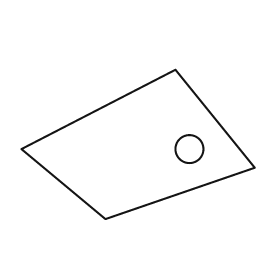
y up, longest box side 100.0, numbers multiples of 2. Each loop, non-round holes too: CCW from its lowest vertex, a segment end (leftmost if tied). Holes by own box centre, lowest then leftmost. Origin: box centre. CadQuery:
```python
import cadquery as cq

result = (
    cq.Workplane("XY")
    .moveTo(-14.0, -32.0)
    .lineTo(50.0, -10.0)
    .lineTo(16.0, 32.0)
    .lineTo(-50.0, -2.0)
    .close()
    .moveTo(22.0, -2.0)
    .circle(6.0)
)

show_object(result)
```